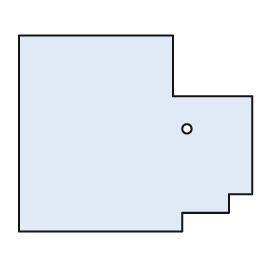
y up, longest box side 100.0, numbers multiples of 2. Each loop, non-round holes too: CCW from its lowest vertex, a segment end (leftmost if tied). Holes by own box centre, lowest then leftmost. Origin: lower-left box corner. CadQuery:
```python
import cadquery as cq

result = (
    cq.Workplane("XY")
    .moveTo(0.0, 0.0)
    .lineTo(70.0, 0.0)
    .lineTo(70.0, 8.0)
    .lineTo(90.0, 8.0)
    .lineTo(90.0, 16.0)
    .lineTo(100.0, 16.0)
    .lineTo(100.0, 58.0)
    .lineTo(66.0, 58.0)
    .lineTo(66.0, 84.0)
    .lineTo(0.0, 84.0)
    .close()
    .moveTo(72.0, 44.0)
    .circle(2.0)
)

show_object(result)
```